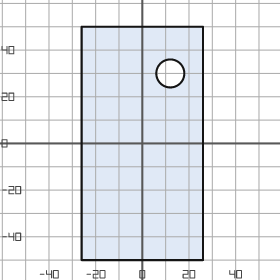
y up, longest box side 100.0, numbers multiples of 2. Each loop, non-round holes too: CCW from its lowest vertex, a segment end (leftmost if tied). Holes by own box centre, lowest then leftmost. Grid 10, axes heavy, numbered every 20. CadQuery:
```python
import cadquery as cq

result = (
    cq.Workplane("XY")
    .moveTo(-26.0, -50.0)
    .lineTo(26.0, -50.0)
    .lineTo(26.0, 50.0)
    .lineTo(-26.0, 50.0)
    .close()
    .moveTo(12.0, 30.0)
    .circle(6.0)
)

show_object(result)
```